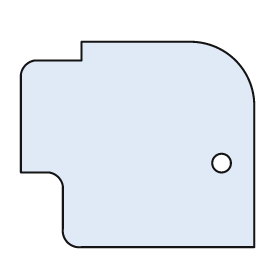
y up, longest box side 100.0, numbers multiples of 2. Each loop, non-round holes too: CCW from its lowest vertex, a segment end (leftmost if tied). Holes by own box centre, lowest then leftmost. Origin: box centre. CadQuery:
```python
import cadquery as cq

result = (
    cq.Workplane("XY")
    .moveTo(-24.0, -44.0)
    .lineTo(50.0, -44.0)
    .lineTo(50.0, 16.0)
    .threePointArc((42.0, 36.0), (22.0, 44.0))
    .lineTo(-24.0, 44.0)
    .lineTo(-24.0, 36.0)
    .lineTo(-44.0, 36.0)
    .threePointArc((-48.0, 34.0), (-50.0, 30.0))
    .lineTo(-50.0, -12.0)
    .lineTo(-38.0, -12.0)
    .threePointArc((-34.0, -14.0), (-32.0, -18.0))
    .lineTo(-32.0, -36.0)
    .threePointArc((-30.0, -42.0), (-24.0, -44.0))
    .close()
    .moveTo(36.0, -8.0)
    .circle(4.0)
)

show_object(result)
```